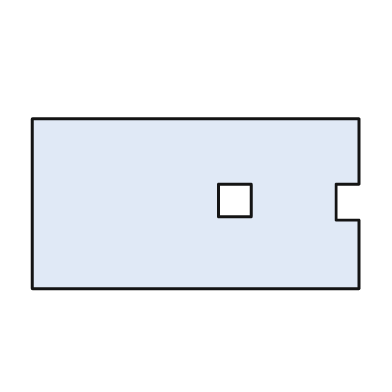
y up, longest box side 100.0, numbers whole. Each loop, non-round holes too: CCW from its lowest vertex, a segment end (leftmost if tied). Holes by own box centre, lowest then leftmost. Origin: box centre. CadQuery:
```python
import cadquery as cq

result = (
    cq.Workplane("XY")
    .moveTo(-50.0, -26.0)
    .lineTo(50.0, -26.0)
    .lineTo(50.0, -5.0)
    .lineTo(43.0, -5.0)
    .lineTo(43.0, 6.0)
    .lineTo(50.0, 6.0)
    .lineTo(50.0, 26.0)
    .lineTo(-50.0, 26.0)
    .close()
    .moveTo(7.0, -4.0)
    .lineTo(17.0, -4.0)
    .lineTo(17.0, 6.0)
    .lineTo(7.0, 6.0)
    .close()
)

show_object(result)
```